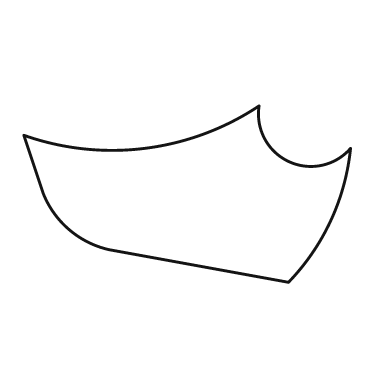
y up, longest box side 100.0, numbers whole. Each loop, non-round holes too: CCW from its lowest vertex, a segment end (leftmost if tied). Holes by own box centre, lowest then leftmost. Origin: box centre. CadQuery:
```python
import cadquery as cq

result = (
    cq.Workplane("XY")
    .moveTo(31.0, -27.0)
    .threePointArc((44.0, -8.0), (50.0, 14.0))
    .threePointArc((31.0, 10.0), (22.0, 27.0))
    .threePointArc((-13.0, 14.0), (-50.0, 18.0))
    .lineTo(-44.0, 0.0)
    .threePointArc((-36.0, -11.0), (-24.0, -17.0))
    .close()
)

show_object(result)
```